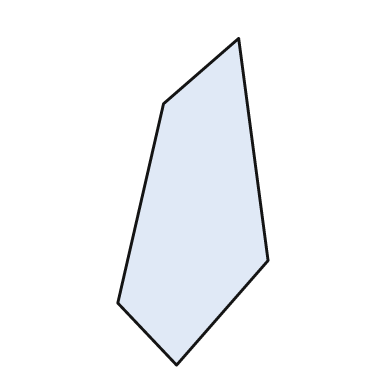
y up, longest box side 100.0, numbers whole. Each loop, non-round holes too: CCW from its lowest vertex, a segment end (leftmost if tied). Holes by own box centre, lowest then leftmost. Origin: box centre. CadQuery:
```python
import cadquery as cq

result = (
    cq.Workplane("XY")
    .moveTo(-5.0, -50.0)
    .lineTo(23.0, -18.0)
    .lineTo(14.0, 50.0)
    .lineTo(-9.0, 30.0)
    .lineTo(-23.0, -31.0)
    .close()
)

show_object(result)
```